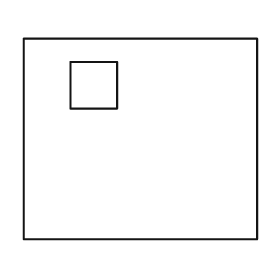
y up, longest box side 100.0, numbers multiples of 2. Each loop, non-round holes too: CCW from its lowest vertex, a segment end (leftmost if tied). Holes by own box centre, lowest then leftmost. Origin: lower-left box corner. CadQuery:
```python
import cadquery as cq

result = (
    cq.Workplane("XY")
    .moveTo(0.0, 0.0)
    .lineTo(100.0, 0.0)
    .lineTo(100.0, 86.0)
    .lineTo(0.0, 86.0)
    .close()
    .moveTo(20.0, 56.0)
    .lineTo(40.0, 56.0)
    .lineTo(40.0, 76.0)
    .lineTo(20.0, 76.0)
    .close()
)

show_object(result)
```